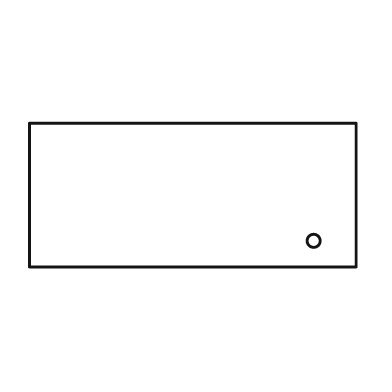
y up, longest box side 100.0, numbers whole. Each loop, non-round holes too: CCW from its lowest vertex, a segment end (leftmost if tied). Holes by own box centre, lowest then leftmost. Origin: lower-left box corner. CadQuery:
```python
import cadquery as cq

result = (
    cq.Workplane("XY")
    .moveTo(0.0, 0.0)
    .lineTo(100.0, 0.0)
    .lineTo(100.0, 44.0)
    .lineTo(0.0, 44.0)
    .close()
    .moveTo(87.0, 8.0)
    .circle(2.0)
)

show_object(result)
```